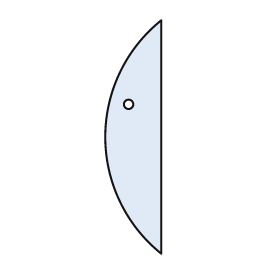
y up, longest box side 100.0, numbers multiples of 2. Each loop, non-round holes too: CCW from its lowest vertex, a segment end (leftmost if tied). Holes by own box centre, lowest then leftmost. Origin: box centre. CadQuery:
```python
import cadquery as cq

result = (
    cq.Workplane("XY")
    .moveTo(12.0, -50.0)
    .lineTo(12.0, 50.0)
    .threePointArc((-12.0, 0.0), (12.0, -50.0))
    .close()
    .moveTo(-2.0, 14.0)
    .circle(2.0)
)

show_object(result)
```